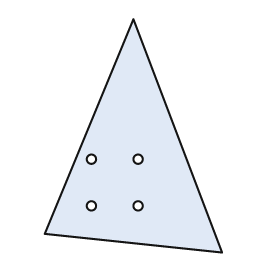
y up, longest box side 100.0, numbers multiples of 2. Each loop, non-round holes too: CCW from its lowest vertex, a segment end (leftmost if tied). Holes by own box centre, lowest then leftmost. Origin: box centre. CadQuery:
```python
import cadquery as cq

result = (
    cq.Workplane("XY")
    .moveTo(38.0, -50.0)
    .lineTo(0.0, 50.0)
    .lineTo(-38.0, -42.0)
    .close()
    .moveTo(-18.0, -30.0)
    .circle(2.0)
    .moveTo(2.0, -30.0)
    .circle(2.0)
    .moveTo(-18.0, -10.0)
    .circle(2.0)
    .moveTo(2.0, -10.0)
    .circle(2.0)
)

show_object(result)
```